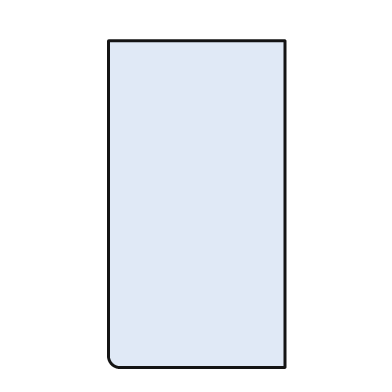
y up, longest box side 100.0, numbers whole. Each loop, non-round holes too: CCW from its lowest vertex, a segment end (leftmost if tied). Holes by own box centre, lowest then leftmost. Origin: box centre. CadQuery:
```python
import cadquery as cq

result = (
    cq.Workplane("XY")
    .moveTo(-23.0, -50.0)
    .lineTo(27.0, -50.0)
    .lineTo(27.0, 50.0)
    .lineTo(-27.0, 50.0)
    .lineTo(-27.0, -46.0)
    .threePointArc((-26.0, -49.0), (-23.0, -50.0))
    .close()
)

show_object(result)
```